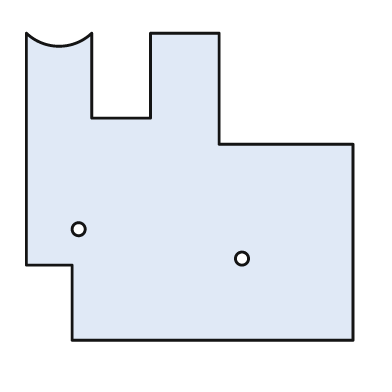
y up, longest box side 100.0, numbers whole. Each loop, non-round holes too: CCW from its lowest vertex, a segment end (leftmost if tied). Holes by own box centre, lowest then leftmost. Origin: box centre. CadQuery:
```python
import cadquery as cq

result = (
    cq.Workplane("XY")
    .moveTo(-36.0, -47.0)
    .lineTo(50.0, -47.0)
    .lineTo(50.0, 13.0)
    .lineTo(9.0, 13.0)
    .lineTo(9.0, 47.0)
    .lineTo(-12.0, 47.0)
    .lineTo(-12.0, 21.0)
    .lineTo(-30.0, 21.0)
    .lineTo(-30.0, 47.0)
    .threePointArc((-40.0, 43.0), (-50.0, 47.0))
    .lineTo(-50.0, -24.0)
    .lineTo(-36.0, -24.0)
    .close()
    .moveTo(16.0, -22.0)
    .circle(2.0)
    .moveTo(-34.0, -13.0)
    .circle(2.0)
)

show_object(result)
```